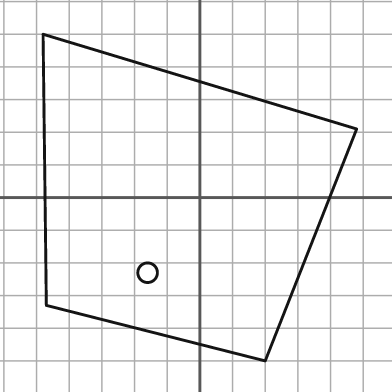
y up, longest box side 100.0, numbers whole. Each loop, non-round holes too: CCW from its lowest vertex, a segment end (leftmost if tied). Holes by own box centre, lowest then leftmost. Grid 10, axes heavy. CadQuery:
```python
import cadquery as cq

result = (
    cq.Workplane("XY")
    .moveTo(20.0, -50.0)
    .lineTo(48.0, 21.0)
    .lineTo(-48.0, 50.0)
    .lineTo(-47.0, -33.0)
    .close()
    .moveTo(-16.0, -23.0)
    .circle(3.0)
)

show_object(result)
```